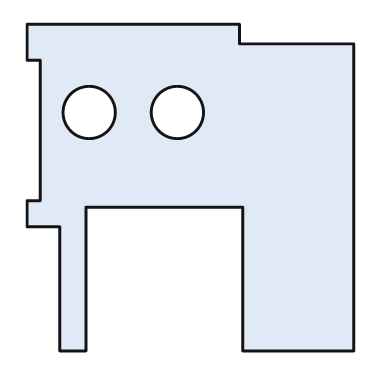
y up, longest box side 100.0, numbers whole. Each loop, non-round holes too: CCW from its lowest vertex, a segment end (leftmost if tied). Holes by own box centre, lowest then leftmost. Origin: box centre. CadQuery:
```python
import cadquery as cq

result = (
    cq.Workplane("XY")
    .moveTo(-40.0, -50.0)
    .lineTo(-32.0, -50.0)
    .lineTo(-32.0, -6.0)
    .lineTo(16.0, -6.0)
    .lineTo(16.0, -50.0)
    .lineTo(50.0, -50.0)
    .lineTo(50.0, 44.0)
    .lineTo(15.0, 44.0)
    .lineTo(15.0, 50.0)
    .lineTo(-50.0, 50.0)
    .lineTo(-50.0, 39.0)
    .lineTo(-46.0, 39.0)
    .lineTo(-46.0, -4.0)
    .lineTo(-50.0, -4.0)
    .lineTo(-50.0, -12.0)
    .lineTo(-40.0, -12.0)
    .close()
    .moveTo(-31.0, 23.0)
    .circle(8.0)
    .moveTo(-4.0, 23.0)
    .circle(8.0)
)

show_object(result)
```